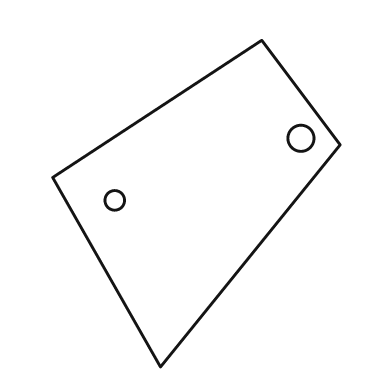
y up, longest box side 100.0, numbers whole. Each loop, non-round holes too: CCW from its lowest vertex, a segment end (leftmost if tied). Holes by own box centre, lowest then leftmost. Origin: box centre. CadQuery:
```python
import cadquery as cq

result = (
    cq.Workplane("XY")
    .moveTo(-11.0, -50.0)
    .lineTo(44.0, 18.0)
    .lineTo(20.0, 50.0)
    .lineTo(-44.0, 8.0)
    .close()
    .moveTo(-25.0, 1.0)
    .circle(3.0)
    .moveTo(32.0, 20.0)
    .circle(4.0)
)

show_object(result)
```